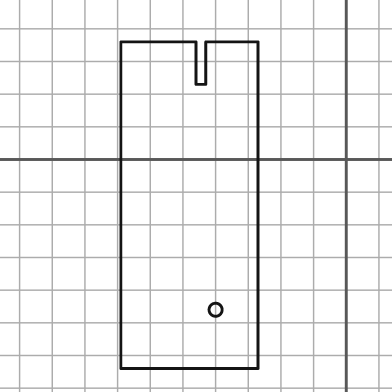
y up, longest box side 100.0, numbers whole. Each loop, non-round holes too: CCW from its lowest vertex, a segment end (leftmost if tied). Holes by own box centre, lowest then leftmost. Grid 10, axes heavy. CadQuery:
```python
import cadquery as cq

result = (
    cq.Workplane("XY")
    .moveTo(-69.0, -64.0)
    .lineTo(-27.0, -64.0)
    .lineTo(-27.0, 36.0)
    .lineTo(-43.0, 36.0)
    .lineTo(-43.0, 23.0)
    .lineTo(-46.0, 23.0)
    .lineTo(-46.0, 36.0)
    .lineTo(-69.0, 36.0)
    .close()
    .moveTo(-40.0, -46.0)
    .circle(2.0)
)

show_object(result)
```